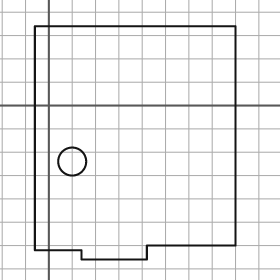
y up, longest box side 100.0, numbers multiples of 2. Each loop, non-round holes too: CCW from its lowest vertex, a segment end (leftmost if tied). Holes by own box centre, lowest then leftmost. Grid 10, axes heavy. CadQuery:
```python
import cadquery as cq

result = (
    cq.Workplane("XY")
    .moveTo(14.0, -66.0)
    .lineTo(42.0, -66.0)
    .lineTo(42.0, -60.0)
    .lineTo(80.0, -60.0)
    .lineTo(80.0, 34.0)
    .lineTo(-6.0, 34.0)
    .lineTo(-6.0, -62.0)
    .lineTo(14.0, -62.0)
    .close()
    .moveTo(10.0, -24.0)
    .circle(6.0)
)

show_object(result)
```